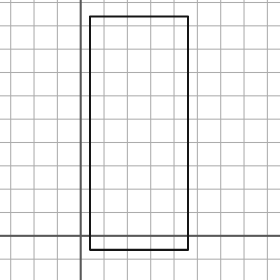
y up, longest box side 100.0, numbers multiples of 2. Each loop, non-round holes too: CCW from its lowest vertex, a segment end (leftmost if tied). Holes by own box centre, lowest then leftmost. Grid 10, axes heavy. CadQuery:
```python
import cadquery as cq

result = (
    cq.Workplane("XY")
    .moveTo(4.0, -6.0)
    .lineTo(46.0, -6.0)
    .lineTo(46.0, 94.0)
    .lineTo(4.0, 94.0)
    .close()
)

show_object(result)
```